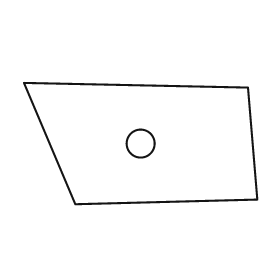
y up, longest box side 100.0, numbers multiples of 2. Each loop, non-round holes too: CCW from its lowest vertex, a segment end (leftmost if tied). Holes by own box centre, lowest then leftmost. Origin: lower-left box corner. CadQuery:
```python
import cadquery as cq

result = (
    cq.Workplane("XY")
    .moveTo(22.0, 0.0)
    .lineTo(100.0, 2.0)
    .lineTo(96.0, 50.0)
    .lineTo(0.0, 52.0)
    .close()
    .moveTo(50.0, 26.0)
    .circle(6.0)
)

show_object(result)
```